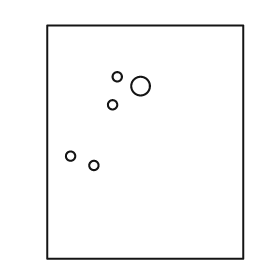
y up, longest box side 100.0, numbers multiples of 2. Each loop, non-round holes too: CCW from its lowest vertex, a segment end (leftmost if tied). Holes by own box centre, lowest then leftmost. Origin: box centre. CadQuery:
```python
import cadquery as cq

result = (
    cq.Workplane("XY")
    .moveTo(-42.0, -50.0)
    .lineTo(42.0, -50.0)
    .lineTo(42.0, 50.0)
    .lineTo(-42.0, 50.0)
    .close()
    .moveTo(-22.0, -10.0)
    .circle(2.0)
    .moveTo(-32.0, -6.0)
    .circle(2.0)
    .moveTo(-14.0, 16.0)
    .circle(2.0)
    .moveTo(-2.0, 24.0)
    .circle(4.0)
    .moveTo(-12.0, 28.0)
    .circle(2.0)
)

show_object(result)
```